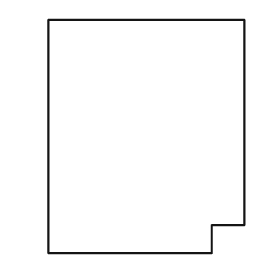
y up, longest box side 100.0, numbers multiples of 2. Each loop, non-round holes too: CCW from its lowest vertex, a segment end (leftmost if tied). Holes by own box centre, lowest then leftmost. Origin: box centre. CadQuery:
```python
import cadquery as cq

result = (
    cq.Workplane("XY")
    .moveTo(-42.0, -50.0)
    .lineTo(28.0, -50.0)
    .lineTo(28.0, -38.0)
    .lineTo(42.0, -38.0)
    .lineTo(42.0, 50.0)
    .lineTo(-42.0, 50.0)
    .close()
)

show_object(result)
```